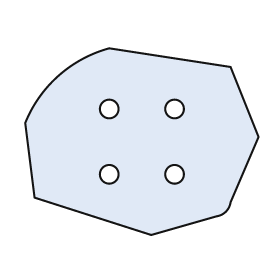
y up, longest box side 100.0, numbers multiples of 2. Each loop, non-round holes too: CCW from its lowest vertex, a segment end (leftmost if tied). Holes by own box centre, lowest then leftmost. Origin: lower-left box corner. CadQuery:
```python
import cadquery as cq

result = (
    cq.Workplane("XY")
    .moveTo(54.0, 0.0)
    .lineTo(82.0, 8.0)
    .threePointArc((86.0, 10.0), (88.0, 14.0))
    .lineTo(100.0, 42.0)
    .lineTo(88.0, 72.0)
    .lineTo(36.0, 80.0)
    .threePointArc((14.0, 68.0), (0.0, 48.0))
    .lineTo(4.0, 16.0)
    .close()
    .moveTo(36.0, 26.0)
    .circle(4.0)
    .moveTo(64.0, 26.0)
    .circle(4.0)
    .moveTo(36.0, 54.0)
    .circle(4.0)
    .moveTo(64.0, 54.0)
    .circle(4.0)
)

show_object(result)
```